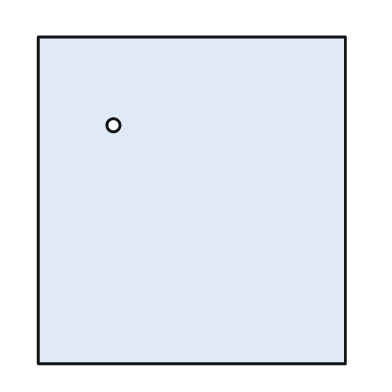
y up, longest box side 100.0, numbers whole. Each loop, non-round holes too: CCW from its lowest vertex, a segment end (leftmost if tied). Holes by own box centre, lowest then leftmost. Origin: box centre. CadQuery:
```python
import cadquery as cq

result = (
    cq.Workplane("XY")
    .moveTo(-47.0, -50.0)
    .lineTo(47.0, -50.0)
    .lineTo(47.0, 50.0)
    .lineTo(-47.0, 50.0)
    .close()
    .moveTo(-24.0, 23.0)
    .circle(2.0)
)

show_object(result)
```